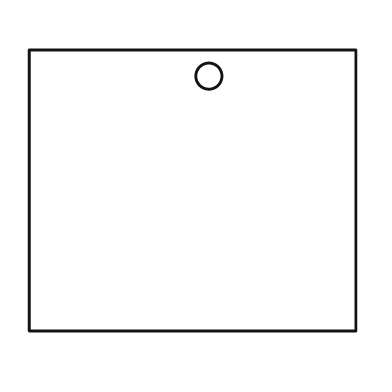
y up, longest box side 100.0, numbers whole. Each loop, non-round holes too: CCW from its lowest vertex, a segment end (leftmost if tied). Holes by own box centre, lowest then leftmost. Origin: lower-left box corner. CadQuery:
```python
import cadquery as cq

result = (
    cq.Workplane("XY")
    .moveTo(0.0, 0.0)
    .lineTo(100.0, 0.0)
    .lineTo(100.0, 86.0)
    .lineTo(0.0, 86.0)
    .close()
    .moveTo(55.0, 78.0)
    .circle(4.0)
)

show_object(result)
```